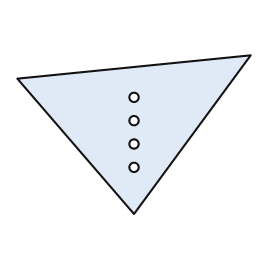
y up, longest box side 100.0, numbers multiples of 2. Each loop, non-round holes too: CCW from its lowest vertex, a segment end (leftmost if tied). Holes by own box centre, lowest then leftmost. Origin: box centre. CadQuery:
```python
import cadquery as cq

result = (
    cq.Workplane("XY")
    .moveTo(0.0, -34.0)
    .lineTo(50.0, 34.0)
    .lineTo(-50.0, 24.0)
    .close()
    .moveTo(0.0, -14.0)
    .circle(2.0)
    .moveTo(0.0, -4.0)
    .circle(2.0)
    .moveTo(0.0, 6.0)
    .circle(2.0)
    .moveTo(0.0, 16.0)
    .circle(2.0)
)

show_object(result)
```